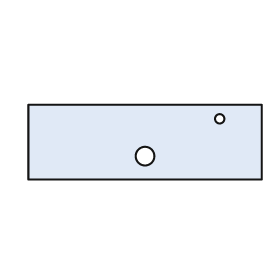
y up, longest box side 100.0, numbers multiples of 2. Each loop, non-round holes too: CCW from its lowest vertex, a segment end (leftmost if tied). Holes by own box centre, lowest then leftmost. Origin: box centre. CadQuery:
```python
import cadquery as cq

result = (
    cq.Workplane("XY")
    .moveTo(-50.0, -16.0)
    .lineTo(50.0, -16.0)
    .lineTo(50.0, 16.0)
    .lineTo(-50.0, 16.0)
    .close()
    .moveTo(0.0, -6.0)
    .circle(4.0)
    .moveTo(32.0, 10.0)
    .circle(2.0)
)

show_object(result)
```